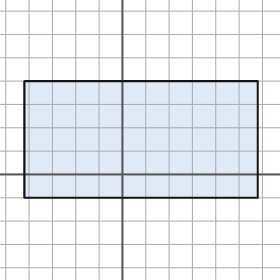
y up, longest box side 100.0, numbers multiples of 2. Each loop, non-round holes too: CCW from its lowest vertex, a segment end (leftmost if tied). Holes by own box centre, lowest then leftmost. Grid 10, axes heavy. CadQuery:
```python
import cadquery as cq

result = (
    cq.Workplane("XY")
    .moveTo(-42.0, -10.0)
    .lineTo(58.0, -10.0)
    .lineTo(58.0, 40.0)
    .lineTo(-42.0, 40.0)
    .close()
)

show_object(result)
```